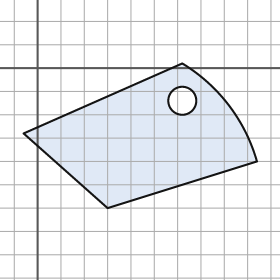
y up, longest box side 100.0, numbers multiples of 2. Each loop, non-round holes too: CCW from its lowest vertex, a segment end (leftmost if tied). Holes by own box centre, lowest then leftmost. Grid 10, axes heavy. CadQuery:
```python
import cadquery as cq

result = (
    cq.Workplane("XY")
    .moveTo(30.0, -60.0)
    .lineTo(94.0, -40.0)
    .threePointArc((82.0, -16.0), (62.0, 2.0))
    .lineTo(-6.0, -28.0)
    .close()
    .moveTo(62.0, -14.0)
    .circle(6.0)
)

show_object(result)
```